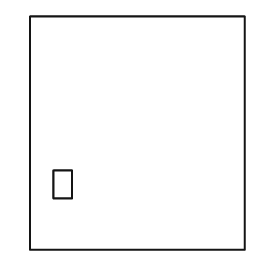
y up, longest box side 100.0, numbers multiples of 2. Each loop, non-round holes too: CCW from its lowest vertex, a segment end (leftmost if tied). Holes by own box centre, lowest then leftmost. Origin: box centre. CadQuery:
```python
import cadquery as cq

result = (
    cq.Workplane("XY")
    .moveTo(-46.0, -50.0)
    .lineTo(46.0, -50.0)
    .lineTo(46.0, 50.0)
    .lineTo(-46.0, 50.0)
    .close()
    .moveTo(-36.0, -28.0)
    .lineTo(-28.0, -28.0)
    .lineTo(-28.0, -16.0)
    .lineTo(-36.0, -16.0)
    .close()
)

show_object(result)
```